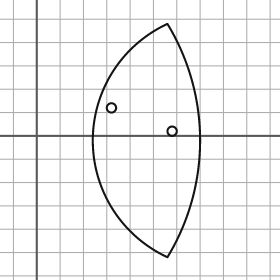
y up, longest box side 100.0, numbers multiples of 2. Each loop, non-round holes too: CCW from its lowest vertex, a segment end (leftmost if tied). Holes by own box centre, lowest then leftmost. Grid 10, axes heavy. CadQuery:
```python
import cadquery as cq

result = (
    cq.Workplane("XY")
    .moveTo(56.0, -52.0)
    .threePointArc((70.0, -2.0), (56.0, 48.0))
    .threePointArc((24.0, -2.0), (56.0, -52.0))
    .close()
    .moveTo(58.0, 2.0)
    .circle(2.0)
    .moveTo(32.0, 12.0)
    .circle(2.0)
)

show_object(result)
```